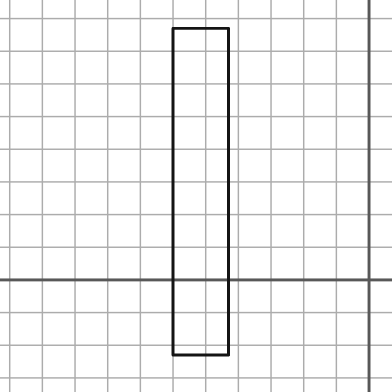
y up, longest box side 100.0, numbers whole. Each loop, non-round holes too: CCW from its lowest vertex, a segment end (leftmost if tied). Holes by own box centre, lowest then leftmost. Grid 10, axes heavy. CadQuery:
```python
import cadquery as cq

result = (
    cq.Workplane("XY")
    .moveTo(-60.0, -23.0)
    .lineTo(-43.0, -23.0)
    .lineTo(-43.0, 77.0)
    .lineTo(-60.0, 77.0)
    .close()
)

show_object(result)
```